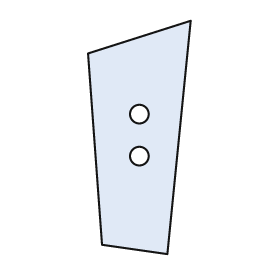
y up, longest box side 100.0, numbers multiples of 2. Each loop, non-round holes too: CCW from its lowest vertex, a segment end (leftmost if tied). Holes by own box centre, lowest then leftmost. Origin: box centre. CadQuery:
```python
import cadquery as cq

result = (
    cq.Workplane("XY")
    .moveTo(12.0, -50.0)
    .lineTo(22.0, 50.0)
    .lineTo(-22.0, 36.0)
    .lineTo(-16.0, -46.0)
    .close()
    .moveTo(0.0, -8.0)
    .circle(4.0)
    .moveTo(0.0, 10.0)
    .circle(4.0)
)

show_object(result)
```